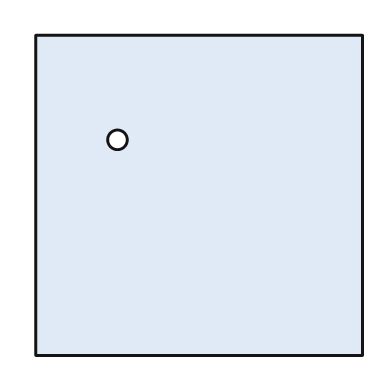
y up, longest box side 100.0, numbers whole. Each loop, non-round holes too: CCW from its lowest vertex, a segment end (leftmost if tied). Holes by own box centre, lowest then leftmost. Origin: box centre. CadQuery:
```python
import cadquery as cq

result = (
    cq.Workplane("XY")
    .moveTo(-50.0, -49.0)
    .lineTo(50.0, -49.0)
    .lineTo(50.0, 49.0)
    .lineTo(-50.0, 49.0)
    .close()
    .moveTo(-25.0, 17.0)
    .circle(3.0)
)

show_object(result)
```